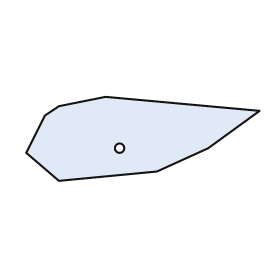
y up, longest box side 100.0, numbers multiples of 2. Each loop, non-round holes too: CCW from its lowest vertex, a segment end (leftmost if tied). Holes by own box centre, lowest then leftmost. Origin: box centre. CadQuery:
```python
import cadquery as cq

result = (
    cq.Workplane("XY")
    .moveTo(-36.0, -18.0)
    .lineTo(6.0, -14.0)
    .lineTo(28.0, -4.0)
    .lineTo(50.0, 12.0)
    .lineTo(-16.0, 18.0)
    .lineTo(-36.0, 14.0)
    .lineTo(-42.0, 10.0)
    .lineTo(-50.0, -6.0)
    .close()
    .moveTo(-10.0, -4.0)
    .circle(2.0)
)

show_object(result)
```